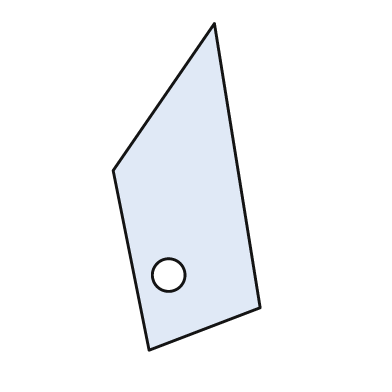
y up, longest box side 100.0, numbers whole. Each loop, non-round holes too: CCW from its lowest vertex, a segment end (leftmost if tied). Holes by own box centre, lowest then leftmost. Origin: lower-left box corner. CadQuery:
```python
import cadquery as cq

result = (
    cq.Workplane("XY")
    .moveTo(11.0, 0.0)
    .lineTo(45.0, 13.0)
    .lineTo(31.0, 100.0)
    .lineTo(0.0, 55.0)
    .close()
    .moveTo(17.0, 23.0)
    .circle(5.0)
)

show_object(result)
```